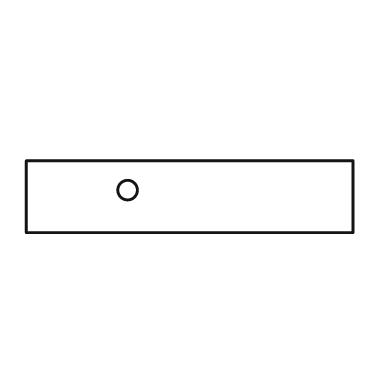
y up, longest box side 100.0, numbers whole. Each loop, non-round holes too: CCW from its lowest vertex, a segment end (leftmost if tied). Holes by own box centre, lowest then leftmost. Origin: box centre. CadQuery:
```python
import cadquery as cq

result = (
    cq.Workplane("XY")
    .moveTo(-50.0, -11.0)
    .lineTo(50.0, -11.0)
    .lineTo(50.0, 11.0)
    .lineTo(-50.0, 11.0)
    .close()
    .moveTo(-19.0, 2.0)
    .circle(3.0)
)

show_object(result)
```